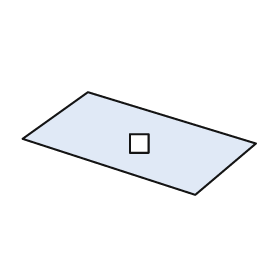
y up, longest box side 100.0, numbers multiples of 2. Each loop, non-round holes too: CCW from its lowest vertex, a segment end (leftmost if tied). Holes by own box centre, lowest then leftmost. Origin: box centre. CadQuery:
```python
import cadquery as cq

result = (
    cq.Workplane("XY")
    .moveTo(24.0, -22.0)
    .lineTo(50.0, 0.0)
    .lineTo(-22.0, 22.0)
    .lineTo(-50.0, 2.0)
    .close()
    .moveTo(-4.0, -4.0)
    .lineTo(4.0, -4.0)
    .lineTo(4.0, 4.0)
    .lineTo(-4.0, 4.0)
    .close()
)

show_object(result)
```